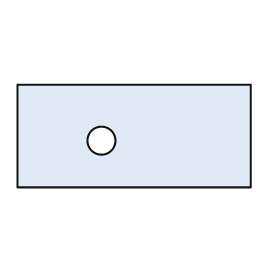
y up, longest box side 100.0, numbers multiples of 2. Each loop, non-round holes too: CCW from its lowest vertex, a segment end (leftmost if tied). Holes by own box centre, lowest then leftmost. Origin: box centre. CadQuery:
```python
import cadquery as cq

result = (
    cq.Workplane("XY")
    .moveTo(-50.0, -22.0)
    .lineTo(50.0, -22.0)
    .lineTo(50.0, 22.0)
    .lineTo(-50.0, 22.0)
    .close()
    .moveTo(-14.0, -2.0)
    .circle(6.0)
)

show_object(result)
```